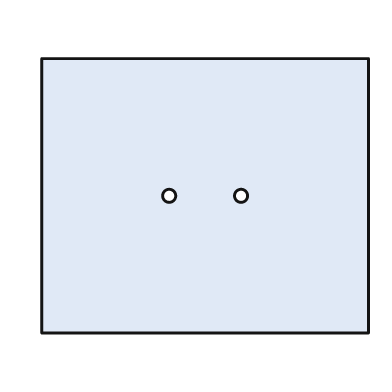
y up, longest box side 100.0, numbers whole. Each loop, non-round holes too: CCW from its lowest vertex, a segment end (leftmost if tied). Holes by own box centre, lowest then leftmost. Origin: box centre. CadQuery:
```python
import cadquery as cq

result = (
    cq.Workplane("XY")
    .moveTo(-50.0, -42.0)
    .lineTo(50.0, -42.0)
    .lineTo(50.0, 42.0)
    .lineTo(-50.0, 42.0)
    .close()
    .moveTo(-11.0, 0.0)
    .circle(2.0)
    .moveTo(11.0, 0.0)
    .circle(2.0)
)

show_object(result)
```